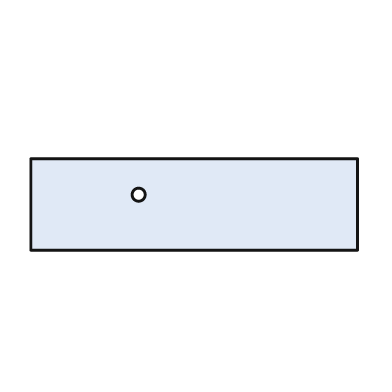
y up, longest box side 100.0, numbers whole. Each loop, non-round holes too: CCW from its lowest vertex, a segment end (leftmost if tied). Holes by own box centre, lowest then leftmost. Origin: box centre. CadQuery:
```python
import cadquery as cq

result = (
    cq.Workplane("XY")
    .moveTo(-50.0, -14.0)
    .lineTo(50.0, -14.0)
    .lineTo(50.0, 14.0)
    .lineTo(-50.0, 14.0)
    .close()
    .moveTo(-17.0, 3.0)
    .circle(2.0)
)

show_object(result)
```